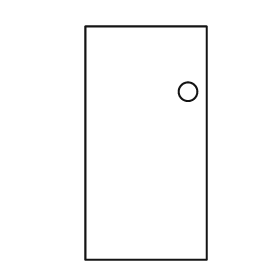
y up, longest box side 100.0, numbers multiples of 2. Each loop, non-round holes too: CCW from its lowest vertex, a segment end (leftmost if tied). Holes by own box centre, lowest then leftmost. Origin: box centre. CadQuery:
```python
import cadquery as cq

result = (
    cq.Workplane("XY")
    .moveTo(-26.0, -50.0)
    .lineTo(26.0, -50.0)
    .lineTo(26.0, 50.0)
    .lineTo(-26.0, 50.0)
    .close()
    .moveTo(18.0, 22.0)
    .circle(4.0)
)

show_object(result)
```